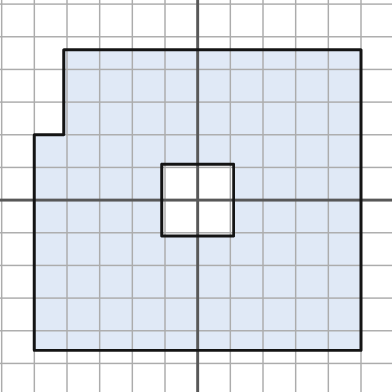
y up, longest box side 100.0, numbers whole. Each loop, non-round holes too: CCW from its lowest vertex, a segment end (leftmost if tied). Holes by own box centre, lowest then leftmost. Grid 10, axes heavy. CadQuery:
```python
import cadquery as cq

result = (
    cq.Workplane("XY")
    .moveTo(-50.0, -46.0)
    .lineTo(50.0, -46.0)
    .lineTo(50.0, 46.0)
    .lineTo(-41.0, 46.0)
    .lineTo(-41.0, 20.0)
    .lineTo(-50.0, 20.0)
    .close()
    .moveTo(-11.0, -11.0)
    .lineTo(11.0, -11.0)
    .lineTo(11.0, 11.0)
    .lineTo(-11.0, 11.0)
    .close()
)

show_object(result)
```